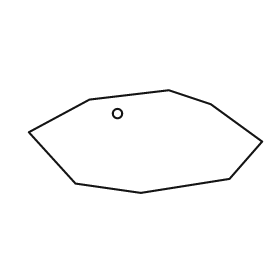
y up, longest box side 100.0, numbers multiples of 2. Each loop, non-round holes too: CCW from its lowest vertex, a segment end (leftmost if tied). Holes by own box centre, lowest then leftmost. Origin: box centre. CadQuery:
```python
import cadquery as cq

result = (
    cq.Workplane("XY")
    .moveTo(-2.0, -22.0)
    .lineTo(36.0, -16.0)
    .lineTo(50.0, 0.0)
    .lineTo(28.0, 16.0)
    .lineTo(10.0, 22.0)
    .lineTo(-24.0, 18.0)
    .lineTo(-50.0, 4.0)
    .lineTo(-30.0, -18.0)
    .close()
    .moveTo(-12.0, 12.0)
    .circle(2.0)
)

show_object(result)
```